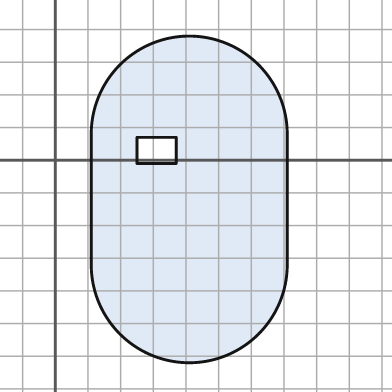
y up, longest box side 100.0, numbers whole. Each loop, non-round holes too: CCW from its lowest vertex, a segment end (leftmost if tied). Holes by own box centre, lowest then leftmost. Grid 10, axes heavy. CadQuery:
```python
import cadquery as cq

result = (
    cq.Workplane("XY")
    .moveTo(11.0, -32.0)
    .threePointArc((41.0, -62.0), (71.0, -32.0))
    .lineTo(71.0, 8.0)
    .threePointArc((41.0, 38.0), (11.0, 8.0))
    .close()
    .moveTo(25.0, -1.0)
    .lineTo(37.0, -1.0)
    .lineTo(37.0, 7.0)
    .lineTo(25.0, 7.0)
    .close()
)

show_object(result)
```